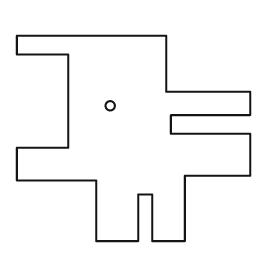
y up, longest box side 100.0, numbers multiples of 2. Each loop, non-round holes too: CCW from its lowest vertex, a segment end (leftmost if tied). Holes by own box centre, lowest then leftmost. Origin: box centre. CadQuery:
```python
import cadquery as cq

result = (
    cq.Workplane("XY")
    .moveTo(-16.0, -44.0)
    .lineTo(2.0, -44.0)
    .lineTo(2.0, -24.0)
    .lineTo(8.0, -24.0)
    .lineTo(8.0, -44.0)
    .lineTo(22.0, -44.0)
    .lineTo(22.0, -16.0)
    .lineTo(50.0, -16.0)
    .lineTo(50.0, 2.0)
    .lineTo(16.0, 2.0)
    .lineTo(16.0, 10.0)
    .lineTo(50.0, 10.0)
    .lineTo(50.0, 20.0)
    .lineTo(14.0, 20.0)
    .lineTo(14.0, 44.0)
    .lineTo(-50.0, 44.0)
    .lineTo(-50.0, 36.0)
    .lineTo(-28.0, 36.0)
    .lineTo(-28.0, -4.0)
    .lineTo(-50.0, -4.0)
    .lineTo(-50.0, -18.0)
    .lineTo(-16.0, -18.0)
    .close()
    .moveTo(-10.0, 14.0)
    .circle(2.0)
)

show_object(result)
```